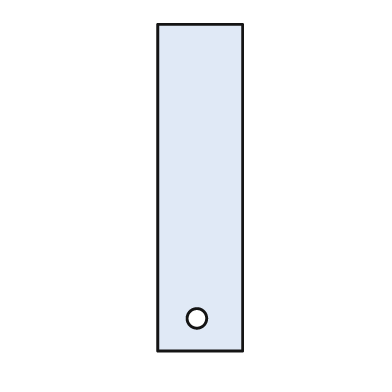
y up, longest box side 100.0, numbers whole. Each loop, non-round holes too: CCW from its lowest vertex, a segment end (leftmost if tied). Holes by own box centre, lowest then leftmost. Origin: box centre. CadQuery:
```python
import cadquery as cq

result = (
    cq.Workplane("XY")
    .moveTo(-13.0, -50.0)
    .lineTo(13.0, -50.0)
    .lineTo(13.0, 50.0)
    .lineTo(-13.0, 50.0)
    .close()
    .moveTo(-1.0, -40.0)
    .circle(3.0)
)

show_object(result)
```